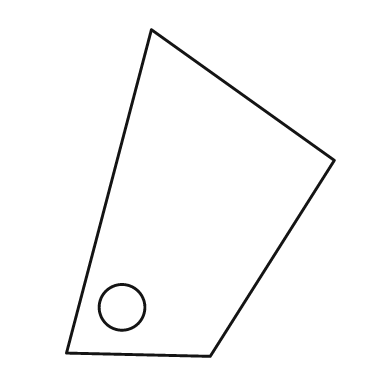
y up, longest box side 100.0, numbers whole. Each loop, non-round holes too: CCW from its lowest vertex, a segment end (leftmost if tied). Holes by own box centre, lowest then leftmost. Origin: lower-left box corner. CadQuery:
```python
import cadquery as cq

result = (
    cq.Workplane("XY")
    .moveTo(44.0, 0.0)
    .lineTo(82.0, 60.0)
    .lineTo(26.0, 100.0)
    .lineTo(0.0, 1.0)
    .close()
    .moveTo(17.0, 15.0)
    .circle(7.0)
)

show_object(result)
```